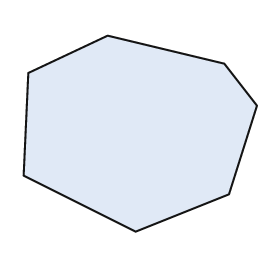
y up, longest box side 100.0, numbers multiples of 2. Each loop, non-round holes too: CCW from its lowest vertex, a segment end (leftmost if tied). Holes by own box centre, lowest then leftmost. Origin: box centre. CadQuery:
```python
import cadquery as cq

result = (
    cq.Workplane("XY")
    .moveTo(-2.0, -42.0)
    .lineTo(38.0, -26.0)
    .lineTo(50.0, 12.0)
    .lineTo(36.0, 30.0)
    .lineTo(-14.0, 42.0)
    .lineTo(-48.0, 26.0)
    .lineTo(-50.0, -18.0)
    .close()
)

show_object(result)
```